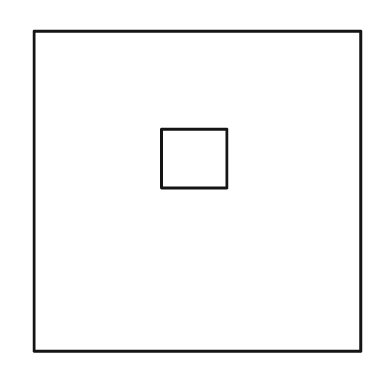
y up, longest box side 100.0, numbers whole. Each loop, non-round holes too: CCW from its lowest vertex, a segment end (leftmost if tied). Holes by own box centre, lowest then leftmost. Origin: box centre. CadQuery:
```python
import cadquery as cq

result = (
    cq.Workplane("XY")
    .moveTo(-50.0, -49.0)
    .lineTo(50.0, -49.0)
    .lineTo(50.0, 49.0)
    .lineTo(-50.0, 49.0)
    .close()
    .moveTo(-11.0, 1.0)
    .lineTo(9.0, 1.0)
    .lineTo(9.0, 19.0)
    .lineTo(-11.0, 19.0)
    .close()
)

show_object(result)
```